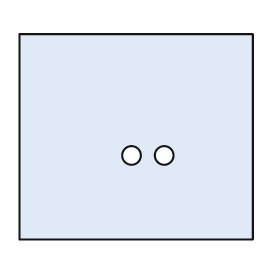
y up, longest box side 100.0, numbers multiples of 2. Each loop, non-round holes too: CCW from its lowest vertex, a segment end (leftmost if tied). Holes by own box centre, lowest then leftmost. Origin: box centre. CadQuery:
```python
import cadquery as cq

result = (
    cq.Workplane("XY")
    .moveTo(-50.0, -44.0)
    .lineTo(50.0, -44.0)
    .lineTo(50.0, 44.0)
    .lineTo(-50.0, 44.0)
    .close()
    .moveTo(-2.0, -8.0)
    .circle(4.0)
    .moveTo(12.0, -8.0)
    .circle(4.0)
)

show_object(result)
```